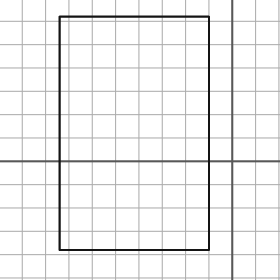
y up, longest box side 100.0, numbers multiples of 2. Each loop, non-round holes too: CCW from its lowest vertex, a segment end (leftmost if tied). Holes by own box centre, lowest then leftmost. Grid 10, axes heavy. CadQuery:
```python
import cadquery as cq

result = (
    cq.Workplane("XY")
    .moveTo(-74.0, -38.0)
    .lineTo(-10.0, -38.0)
    .lineTo(-10.0, 62.0)
    .lineTo(-74.0, 62.0)
    .close()
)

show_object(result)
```